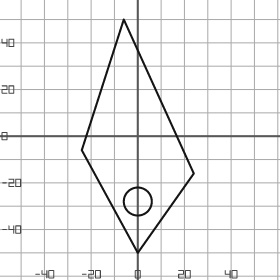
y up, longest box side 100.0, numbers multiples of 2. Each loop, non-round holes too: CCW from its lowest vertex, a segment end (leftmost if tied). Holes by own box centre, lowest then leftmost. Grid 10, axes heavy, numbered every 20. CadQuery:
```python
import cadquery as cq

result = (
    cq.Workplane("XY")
    .moveTo(0.0, -50.0)
    .lineTo(24.0, -16.0)
    .lineTo(-6.0, 50.0)
    .lineTo(-24.0, -6.0)
    .close()
    .moveTo(0.0, -28.0)
    .circle(6.0)
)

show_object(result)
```